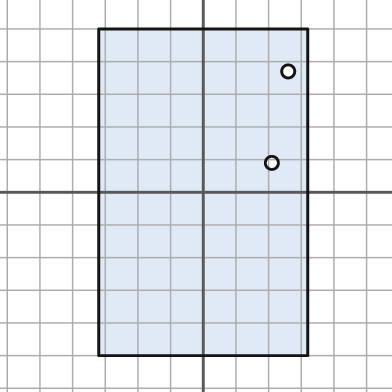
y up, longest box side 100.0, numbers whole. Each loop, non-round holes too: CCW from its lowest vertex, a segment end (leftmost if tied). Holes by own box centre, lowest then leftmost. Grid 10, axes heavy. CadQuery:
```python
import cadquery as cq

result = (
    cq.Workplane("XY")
    .moveTo(-32.0, -50.0)
    .lineTo(32.0, -50.0)
    .lineTo(32.0, 50.0)
    .lineTo(-32.0, 50.0)
    .close()
    .moveTo(21.0, 9.0)
    .circle(2.0)
    .moveTo(26.0, 37.0)
    .circle(2.0)
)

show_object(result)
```